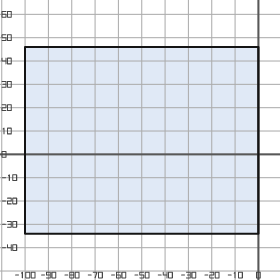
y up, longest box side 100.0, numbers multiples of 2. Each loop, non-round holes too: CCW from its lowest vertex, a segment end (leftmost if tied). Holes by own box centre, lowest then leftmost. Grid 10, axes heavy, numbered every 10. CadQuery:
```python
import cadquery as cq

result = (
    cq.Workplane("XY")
    .moveTo(-100.0, -34.0)
    .lineTo(0.0, -34.0)
    .lineTo(0.0, 46.0)
    .lineTo(-100.0, 46.0)
    .close()
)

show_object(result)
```